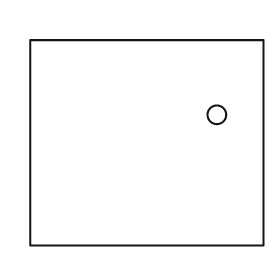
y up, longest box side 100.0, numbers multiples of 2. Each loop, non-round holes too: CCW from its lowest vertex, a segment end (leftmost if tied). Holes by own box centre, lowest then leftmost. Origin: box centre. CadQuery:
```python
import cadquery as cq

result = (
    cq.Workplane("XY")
    .moveTo(-50.0, -44.0)
    .lineTo(50.0, -44.0)
    .lineTo(50.0, 44.0)
    .lineTo(-50.0, 44.0)
    .close()
    .moveTo(30.0, 12.0)
    .circle(4.0)
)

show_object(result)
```